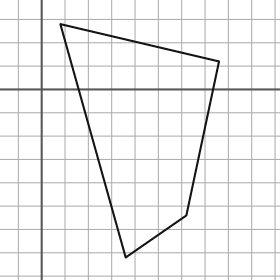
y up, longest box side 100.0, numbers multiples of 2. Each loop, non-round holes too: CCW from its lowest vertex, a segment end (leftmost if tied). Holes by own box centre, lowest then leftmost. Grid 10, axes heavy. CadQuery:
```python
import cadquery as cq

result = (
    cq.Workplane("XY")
    .moveTo(36.0, -72.0)
    .lineTo(62.0, -54.0)
    .lineTo(76.0, 12.0)
    .lineTo(8.0, 28.0)
    .close()
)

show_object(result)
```